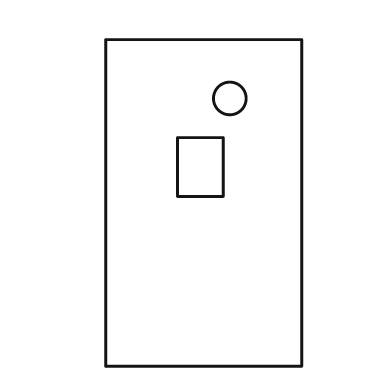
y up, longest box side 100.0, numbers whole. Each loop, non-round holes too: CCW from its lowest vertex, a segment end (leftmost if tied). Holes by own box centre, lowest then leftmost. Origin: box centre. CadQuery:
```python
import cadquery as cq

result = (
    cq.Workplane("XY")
    .moveTo(-30.0, -50.0)
    .lineTo(30.0, -50.0)
    .lineTo(30.0, 50.0)
    .lineTo(-30.0, 50.0)
    .close()
    .moveTo(-8.0, 2.0)
    .lineTo(6.0, 2.0)
    .lineTo(6.0, 20.0)
    .lineTo(-8.0, 20.0)
    .close()
    .moveTo(8.0, 32.0)
    .circle(5.0)
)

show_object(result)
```